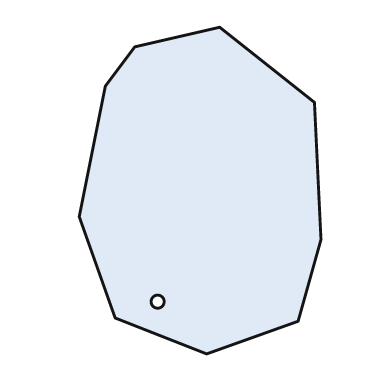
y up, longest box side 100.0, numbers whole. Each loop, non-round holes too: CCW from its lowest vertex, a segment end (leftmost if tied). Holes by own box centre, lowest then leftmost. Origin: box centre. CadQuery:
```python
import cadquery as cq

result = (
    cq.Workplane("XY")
    .moveTo(2.0, -50.0)
    .lineTo(30.0, -40.0)
    .lineTo(37.0, -15.0)
    .lineTo(35.0, 27.0)
    .lineTo(6.0, 50.0)
    .lineTo(-20.0, 44.0)
    .lineTo(-29.0, 32.0)
    .lineTo(-37.0, -8.0)
    .lineTo(-26.0, -39.0)
    .close()
    .moveTo(-13.0, -34.0)
    .circle(2.0)
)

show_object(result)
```